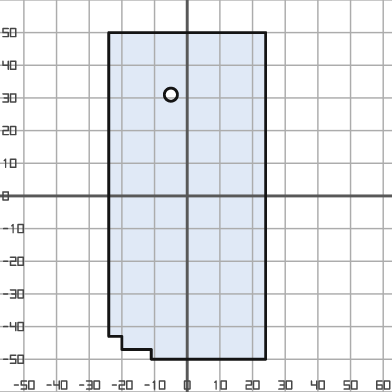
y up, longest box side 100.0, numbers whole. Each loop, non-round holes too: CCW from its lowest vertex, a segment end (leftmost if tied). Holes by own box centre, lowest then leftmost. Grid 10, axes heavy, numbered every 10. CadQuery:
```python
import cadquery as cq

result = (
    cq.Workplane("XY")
    .moveTo(-11.0, -50.0)
    .lineTo(24.0, -50.0)
    .lineTo(24.0, 50.0)
    .lineTo(-24.0, 50.0)
    .lineTo(-24.0, -43.0)
    .lineTo(-20.0, -43.0)
    .lineTo(-20.0, -47.0)
    .lineTo(-11.0, -47.0)
    .close()
    .moveTo(-5.0, 31.0)
    .circle(2.0)
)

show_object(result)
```